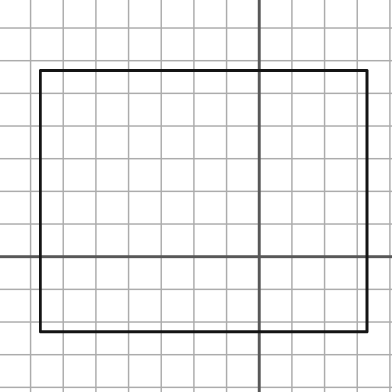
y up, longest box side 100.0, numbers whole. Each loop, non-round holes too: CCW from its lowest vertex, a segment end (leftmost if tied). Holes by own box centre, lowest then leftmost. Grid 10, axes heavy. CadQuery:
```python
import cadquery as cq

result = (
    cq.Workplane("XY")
    .moveTo(-67.0, -23.0)
    .lineTo(33.0, -23.0)
    .lineTo(33.0, 57.0)
    .lineTo(-67.0, 57.0)
    .close()
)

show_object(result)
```